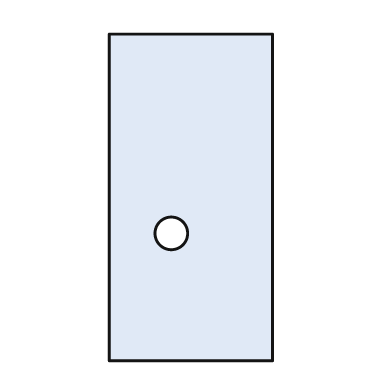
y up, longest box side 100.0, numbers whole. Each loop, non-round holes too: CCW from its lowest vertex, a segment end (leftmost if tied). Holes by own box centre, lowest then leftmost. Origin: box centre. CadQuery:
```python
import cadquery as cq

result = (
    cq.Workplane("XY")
    .moveTo(-25.0, -50.0)
    .lineTo(25.0, -50.0)
    .lineTo(25.0, 50.0)
    .lineTo(-25.0, 50.0)
    .close()
    .moveTo(-6.0, -11.0)
    .circle(5.0)
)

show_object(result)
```